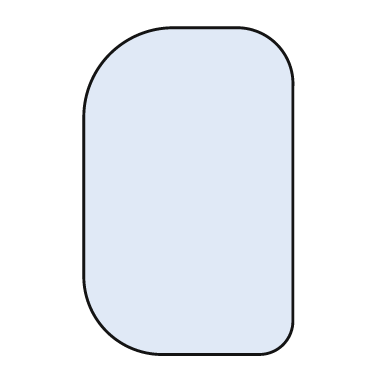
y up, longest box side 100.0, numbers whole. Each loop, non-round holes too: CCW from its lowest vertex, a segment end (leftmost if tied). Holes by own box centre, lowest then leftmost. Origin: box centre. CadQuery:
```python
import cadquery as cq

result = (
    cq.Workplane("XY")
    .moveTo(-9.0, -50.0)
    .lineTo(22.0, -50.0)
    .threePointArc((29.0, -47.0), (32.0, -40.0))
    .lineTo(32.0, 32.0)
    .threePointArc((27.0, 45.0), (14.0, 50.0))
    .lineTo(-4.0, 50.0)
    .threePointArc((-24.0, 42.0), (-32.0, 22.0))
    .lineTo(-32.0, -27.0)
    .threePointArc((-25.0, -43.0), (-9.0, -50.0))
    .close()
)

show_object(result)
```